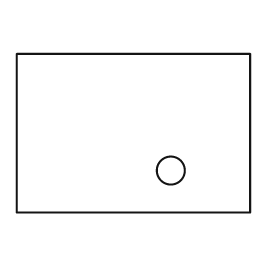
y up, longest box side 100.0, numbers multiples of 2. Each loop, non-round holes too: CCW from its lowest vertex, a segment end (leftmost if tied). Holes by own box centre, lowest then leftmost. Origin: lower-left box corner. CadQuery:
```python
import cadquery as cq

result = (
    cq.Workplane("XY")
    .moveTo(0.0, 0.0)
    .lineTo(100.0, 0.0)
    .lineTo(100.0, 68.0)
    .lineTo(0.0, 68.0)
    .close()
    .moveTo(66.0, 18.0)
    .circle(6.0)
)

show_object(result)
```